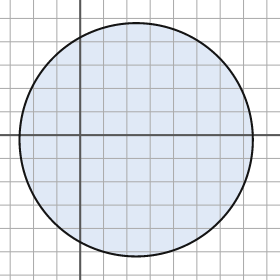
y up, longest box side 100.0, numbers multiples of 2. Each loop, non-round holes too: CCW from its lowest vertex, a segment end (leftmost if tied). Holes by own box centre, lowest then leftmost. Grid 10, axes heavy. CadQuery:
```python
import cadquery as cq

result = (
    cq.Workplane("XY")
    .moveTo(24.0, -2.0)
    .circle(50.0)
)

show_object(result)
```